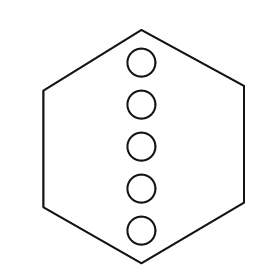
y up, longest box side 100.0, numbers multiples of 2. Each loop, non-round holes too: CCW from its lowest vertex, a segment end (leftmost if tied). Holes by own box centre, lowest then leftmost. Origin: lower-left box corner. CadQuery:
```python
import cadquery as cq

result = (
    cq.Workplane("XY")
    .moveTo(42.0, 0.0)
    .lineTo(86.0, 26.0)
    .lineTo(86.0, 76.0)
    .lineTo(42.0, 100.0)
    .lineTo(0.0, 74.0)
    .lineTo(0.0, 24.0)
    .close()
    .moveTo(42.0, 14.0)
    .circle(6.0)
    .moveTo(42.0, 32.0)
    .circle(6.0)
    .moveTo(42.0, 50.0)
    .circle(6.0)
    .moveTo(42.0, 68.0)
    .circle(6.0)
    .moveTo(42.0, 86.0)
    .circle(6.0)
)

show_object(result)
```